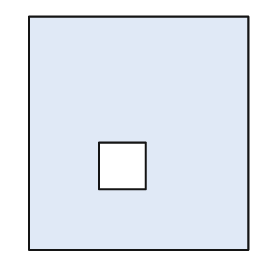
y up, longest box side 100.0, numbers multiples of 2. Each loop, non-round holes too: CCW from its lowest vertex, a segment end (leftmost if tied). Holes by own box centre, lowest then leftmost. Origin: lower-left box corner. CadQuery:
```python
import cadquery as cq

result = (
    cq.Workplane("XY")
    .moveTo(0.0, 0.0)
    .lineTo(94.0, 0.0)
    .lineTo(94.0, 100.0)
    .lineTo(0.0, 100.0)
    .close()
    .moveTo(30.0, 26.0)
    .lineTo(50.0, 26.0)
    .lineTo(50.0, 46.0)
    .lineTo(30.0, 46.0)
    .close()
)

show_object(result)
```